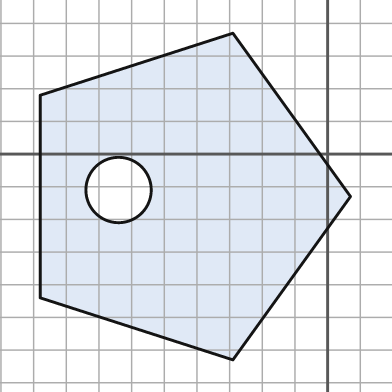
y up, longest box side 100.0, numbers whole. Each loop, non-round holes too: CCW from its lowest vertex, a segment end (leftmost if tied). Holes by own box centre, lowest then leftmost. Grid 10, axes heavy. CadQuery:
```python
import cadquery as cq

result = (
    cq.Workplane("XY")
    .moveTo(-29.0, -63.0)
    .lineTo(7.0, -13.0)
    .lineTo(-29.0, 37.0)
    .lineTo(-88.0, 18.0)
    .lineTo(-88.0, -44.0)
    .close()
    .moveTo(-64.0, -11.0)
    .circle(10.0)
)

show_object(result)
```